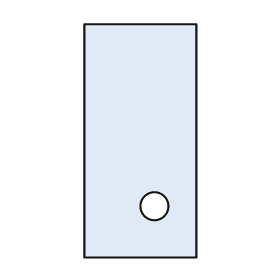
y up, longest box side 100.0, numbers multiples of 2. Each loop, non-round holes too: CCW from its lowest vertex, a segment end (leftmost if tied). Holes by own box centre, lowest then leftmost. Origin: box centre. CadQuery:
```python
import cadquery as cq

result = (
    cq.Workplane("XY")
    .moveTo(-24.0, -50.0)
    .lineTo(24.0, -50.0)
    .lineTo(24.0, 50.0)
    .lineTo(-24.0, 50.0)
    .close()
    .moveTo(6.0, -28.0)
    .circle(6.0)
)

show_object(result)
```